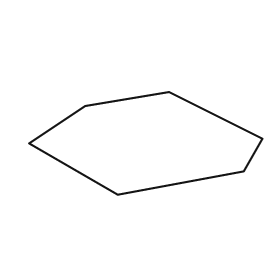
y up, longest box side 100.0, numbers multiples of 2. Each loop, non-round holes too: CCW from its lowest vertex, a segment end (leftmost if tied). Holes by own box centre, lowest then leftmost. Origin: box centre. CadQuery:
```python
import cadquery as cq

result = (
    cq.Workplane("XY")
    .moveTo(-12.0, -22.0)
    .lineTo(42.0, -12.0)
    .lineTo(50.0, 2.0)
    .lineTo(10.0, 22.0)
    .lineTo(-26.0, 16.0)
    .lineTo(-50.0, 0.0)
    .close()
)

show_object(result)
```